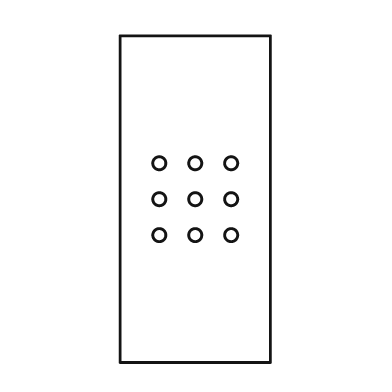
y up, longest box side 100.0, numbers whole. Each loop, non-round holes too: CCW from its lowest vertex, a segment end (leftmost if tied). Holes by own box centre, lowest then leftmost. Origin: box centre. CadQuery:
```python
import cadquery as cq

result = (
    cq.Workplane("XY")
    .moveTo(-23.0, -50.0)
    .lineTo(23.0, -50.0)
    .lineTo(23.0, 50.0)
    .lineTo(-23.0, 50.0)
    .close()
    .moveTo(-11.0, -11.0)
    .circle(2.0)
    .moveTo(0.0, -11.0)
    .circle(2.0)
    .moveTo(11.0, -11.0)
    .circle(2.0)
    .moveTo(-11.0, 0.0)
    .circle(2.0)
    .moveTo(0.0, 0.0)
    .circle(2.0)
    .moveTo(11.0, 0.0)
    .circle(2.0)
    .moveTo(-11.0, 11.0)
    .circle(2.0)
    .moveTo(0.0, 11.0)
    .circle(2.0)
    .moveTo(11.0, 11.0)
    .circle(2.0)
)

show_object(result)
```